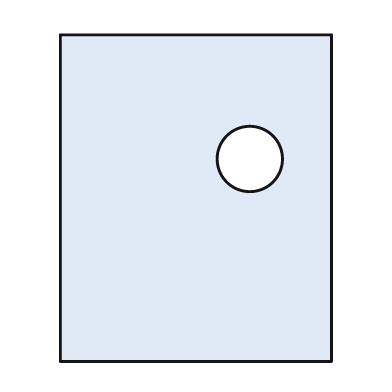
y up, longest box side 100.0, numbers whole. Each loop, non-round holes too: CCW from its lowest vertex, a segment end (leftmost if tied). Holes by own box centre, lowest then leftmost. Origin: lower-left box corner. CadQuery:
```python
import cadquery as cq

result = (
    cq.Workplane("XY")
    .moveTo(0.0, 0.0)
    .lineTo(83.0, 0.0)
    .lineTo(83.0, 100.0)
    .lineTo(0.0, 100.0)
    .close()
    .moveTo(58.0, 62.0)
    .circle(10.0)
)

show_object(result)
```